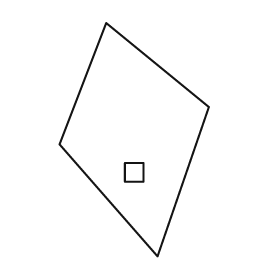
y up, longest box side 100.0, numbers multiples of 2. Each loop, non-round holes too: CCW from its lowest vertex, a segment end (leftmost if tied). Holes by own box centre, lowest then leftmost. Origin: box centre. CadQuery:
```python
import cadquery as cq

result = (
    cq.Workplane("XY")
    .moveTo(10.0, -50.0)
    .lineTo(32.0, 14.0)
    .lineTo(-12.0, 50.0)
    .lineTo(-32.0, -2.0)
    .close()
    .moveTo(-4.0, -18.0)
    .lineTo(4.0, -18.0)
    .lineTo(4.0, -10.0)
    .lineTo(-4.0, -10.0)
    .close()
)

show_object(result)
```